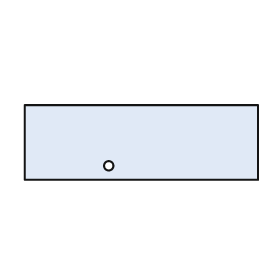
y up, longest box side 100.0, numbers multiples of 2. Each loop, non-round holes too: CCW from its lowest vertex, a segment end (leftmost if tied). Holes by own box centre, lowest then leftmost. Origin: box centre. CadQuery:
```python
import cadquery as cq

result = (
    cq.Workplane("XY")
    .moveTo(-50.0, -16.0)
    .lineTo(50.0, -16.0)
    .lineTo(50.0, 16.0)
    .lineTo(-50.0, 16.0)
    .close()
    .moveTo(-14.0, -10.0)
    .circle(2.0)
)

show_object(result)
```